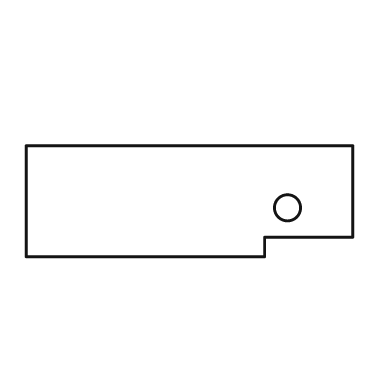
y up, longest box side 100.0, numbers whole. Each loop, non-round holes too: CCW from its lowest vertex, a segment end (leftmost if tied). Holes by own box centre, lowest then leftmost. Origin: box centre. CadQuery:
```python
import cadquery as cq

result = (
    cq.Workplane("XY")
    .moveTo(-50.0, -17.0)
    .lineTo(23.0, -17.0)
    .lineTo(23.0, -11.0)
    .lineTo(50.0, -11.0)
    .lineTo(50.0, 17.0)
    .lineTo(-50.0, 17.0)
    .close()
    .moveTo(30.0, -2.0)
    .circle(4.0)
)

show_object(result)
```